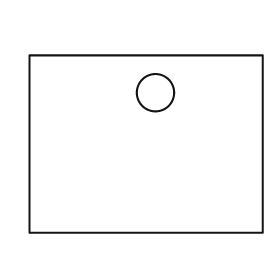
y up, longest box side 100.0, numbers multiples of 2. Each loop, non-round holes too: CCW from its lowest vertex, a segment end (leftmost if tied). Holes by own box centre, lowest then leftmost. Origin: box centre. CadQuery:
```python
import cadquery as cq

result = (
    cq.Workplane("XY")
    .moveTo(-50.0, -38.0)
    .lineTo(50.0, -38.0)
    .lineTo(50.0, 38.0)
    .lineTo(-50.0, 38.0)
    .close()
    .moveTo(4.0, 22.0)
    .circle(8.0)
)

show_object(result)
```